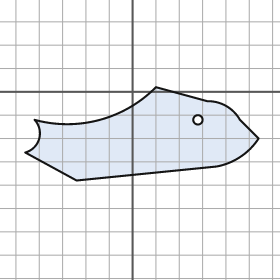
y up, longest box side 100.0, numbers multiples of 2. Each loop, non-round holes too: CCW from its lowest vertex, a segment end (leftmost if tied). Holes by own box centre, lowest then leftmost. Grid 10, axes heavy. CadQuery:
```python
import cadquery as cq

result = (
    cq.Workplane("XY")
    .moveTo(-24.0, -38.0)
    .lineTo(36.0, -32.0)
    .threePointArc((46.0, -28.0), (54.0, -20.0))
    .lineTo(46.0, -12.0)
    .threePointArc((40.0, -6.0), (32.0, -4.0))
    .lineTo(10.0, 2.0)
    .threePointArc((-14.0, -12.0), (-42.0, -12.0))
    .threePointArc((-40.0, -20.0), (-46.0, -26.0))
    .close()
    .moveTo(28.0, -12.0)
    .circle(2.0)
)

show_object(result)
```